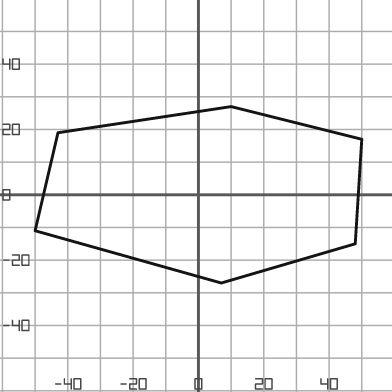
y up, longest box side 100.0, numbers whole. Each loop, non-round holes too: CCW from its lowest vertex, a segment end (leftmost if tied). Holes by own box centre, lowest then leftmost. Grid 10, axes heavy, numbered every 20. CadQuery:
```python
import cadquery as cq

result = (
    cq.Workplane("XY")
    .moveTo(7.0, -27.0)
    .lineTo(48.0, -15.0)
    .lineTo(50.0, 17.0)
    .lineTo(10.0, 27.0)
    .lineTo(-43.0, 19.0)
    .lineTo(-50.0, -11.0)
    .close()
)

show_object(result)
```